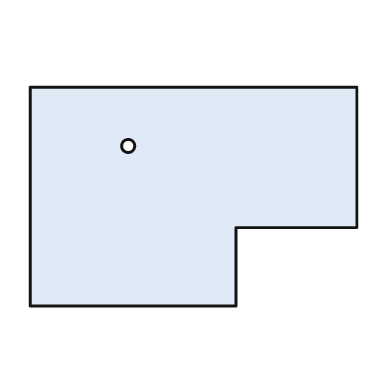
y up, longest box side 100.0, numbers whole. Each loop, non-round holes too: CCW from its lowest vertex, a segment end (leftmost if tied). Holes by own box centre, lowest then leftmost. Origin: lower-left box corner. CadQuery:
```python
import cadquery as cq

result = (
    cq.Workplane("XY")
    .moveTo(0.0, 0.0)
    .lineTo(63.0, 0.0)
    .lineTo(63.0, 24.0)
    .lineTo(100.0, 24.0)
    .lineTo(100.0, 67.0)
    .lineTo(0.0, 67.0)
    .close()
    .moveTo(30.0, 49.0)
    .circle(2.0)
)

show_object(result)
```